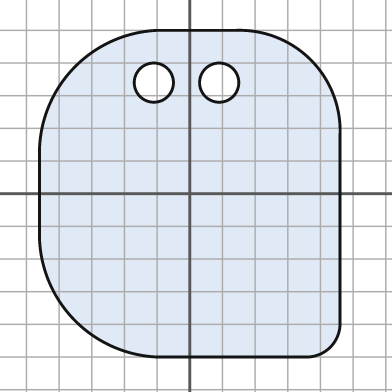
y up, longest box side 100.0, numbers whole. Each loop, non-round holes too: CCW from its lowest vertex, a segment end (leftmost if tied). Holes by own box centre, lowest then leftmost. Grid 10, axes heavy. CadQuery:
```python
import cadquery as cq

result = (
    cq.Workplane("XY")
    .moveTo(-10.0, -50.0)
    .lineTo(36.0, -50.0)
    .threePointArc((43.0, -47.0), (46.0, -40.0))
    .lineTo(46.0, 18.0)
    .threePointArc((37.0, 41.0), (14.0, 50.0))
    .lineTo(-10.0, 50.0)
    .threePointArc((-35.0, 39.0), (-46.0, 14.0))
    .lineTo(-46.0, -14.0)
    .threePointArc((-35.0, -39.0), (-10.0, -50.0))
    .close()
    .moveTo(-11.0, 34.0)
    .circle(6.0)
    .moveTo(9.0, 34.0)
    .circle(6.0)
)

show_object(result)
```